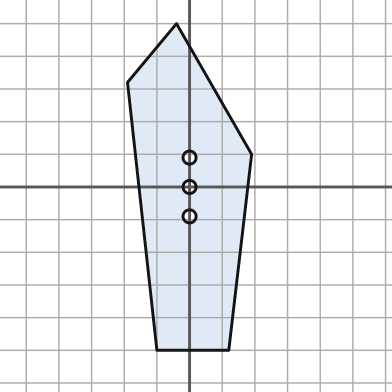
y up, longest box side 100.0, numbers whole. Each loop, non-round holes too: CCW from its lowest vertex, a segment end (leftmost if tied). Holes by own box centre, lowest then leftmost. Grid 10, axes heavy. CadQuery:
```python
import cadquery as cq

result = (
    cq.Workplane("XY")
    .moveTo(-10.0, -50.0)
    .lineTo(12.0, -50.0)
    .lineTo(19.0, 10.0)
    .lineTo(-4.0, 50.0)
    .lineTo(-19.0, 32.0)
    .close()
    .moveTo(0.0, -9.0)
    .circle(2.0)
    .moveTo(0.0, 0.0)
    .circle(2.0)
    .moveTo(0.0, 9.0)
    .circle(2.0)
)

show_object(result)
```